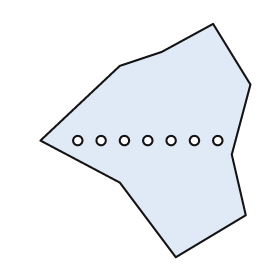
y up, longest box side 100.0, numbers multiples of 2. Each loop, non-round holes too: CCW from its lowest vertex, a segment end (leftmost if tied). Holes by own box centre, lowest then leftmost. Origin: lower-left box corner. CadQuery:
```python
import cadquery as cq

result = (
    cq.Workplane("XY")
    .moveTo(58.0, 0.0)
    .lineTo(88.0, 18.0)
    .lineTo(82.0, 44.0)
    .lineTo(90.0, 74.0)
    .lineTo(74.0, 100.0)
    .lineTo(52.0, 88.0)
    .lineTo(34.0, 82.0)
    .lineTo(0.0, 50.0)
    .lineTo(34.0, 32.0)
    .close()
    .moveTo(16.0, 50.0)
    .circle(2.0)
    .moveTo(26.0, 50.0)
    .circle(2.0)
    .moveTo(36.0, 50.0)
    .circle(2.0)
    .moveTo(46.0, 50.0)
    .circle(2.0)
    .moveTo(56.0, 50.0)
    .circle(2.0)
    .moveTo(66.0, 50.0)
    .circle(2.0)
    .moveTo(76.0, 50.0)
    .circle(2.0)
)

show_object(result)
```